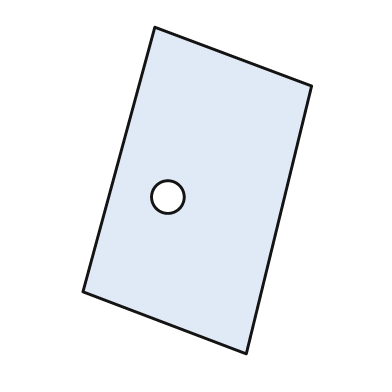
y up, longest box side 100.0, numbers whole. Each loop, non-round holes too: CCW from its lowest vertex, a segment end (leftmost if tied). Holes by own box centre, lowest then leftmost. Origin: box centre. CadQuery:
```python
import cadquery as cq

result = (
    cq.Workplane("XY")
    .moveTo(15.0, -50.0)
    .lineTo(35.0, 32.0)
    .lineTo(-13.0, 50.0)
    .lineTo(-35.0, -31.0)
    .close()
    .moveTo(-9.0, -2.0)
    .circle(5.0)
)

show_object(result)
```